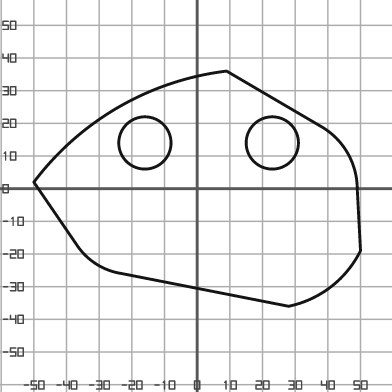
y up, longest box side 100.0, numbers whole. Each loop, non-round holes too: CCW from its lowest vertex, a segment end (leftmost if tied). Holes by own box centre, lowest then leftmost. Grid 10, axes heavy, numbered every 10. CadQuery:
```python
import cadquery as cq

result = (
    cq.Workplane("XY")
    .moveTo(28.0, -36.0)
    .threePointArc((41.0, -30.0), (50.0, -19.0))
    .lineTo(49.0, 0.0)
    .threePointArc((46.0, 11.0), (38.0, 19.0))
    .lineTo(9.0, 36.0)
    .threePointArc((-24.0, 25.0), (-50.0, 2.0))
    .lineTo(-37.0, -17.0)
    .threePointArc((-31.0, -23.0), (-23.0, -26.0))
    .close()
    .moveTo(-16.0, 14.0)
    .circle(8.0)
    .moveTo(23.0, 14.0)
    .circle(8.0)
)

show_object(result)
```